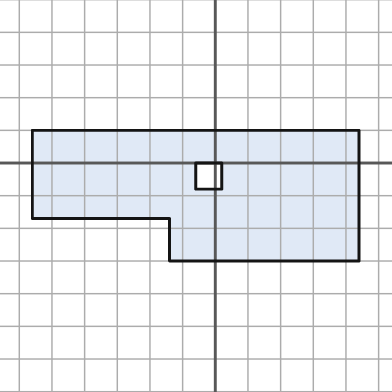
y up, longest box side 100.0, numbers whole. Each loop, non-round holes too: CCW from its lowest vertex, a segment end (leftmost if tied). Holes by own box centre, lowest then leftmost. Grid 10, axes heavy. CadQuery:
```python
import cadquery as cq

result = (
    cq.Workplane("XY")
    .moveTo(-14.0, -30.0)
    .lineTo(44.0, -30.0)
    .lineTo(44.0, 10.0)
    .lineTo(-56.0, 10.0)
    .lineTo(-56.0, -17.0)
    .lineTo(-14.0, -17.0)
    .close()
    .moveTo(-6.0, -8.0)
    .lineTo(2.0, -8.0)
    .lineTo(2.0, 0.0)
    .lineTo(-6.0, 0.0)
    .close()
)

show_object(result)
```